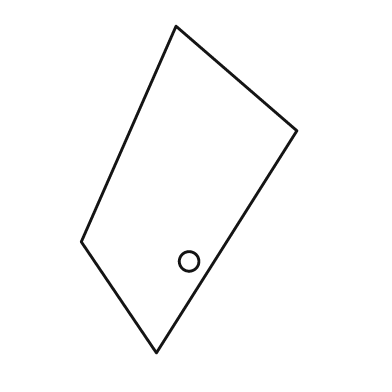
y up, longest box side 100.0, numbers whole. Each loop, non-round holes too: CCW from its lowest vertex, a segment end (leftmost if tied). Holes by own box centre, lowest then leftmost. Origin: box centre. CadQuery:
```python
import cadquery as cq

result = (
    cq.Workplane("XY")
    .moveTo(-10.0, -50.0)
    .lineTo(33.0, 18.0)
    .lineTo(-4.0, 50.0)
    .lineTo(-33.0, -16.0)
    .close()
    .moveTo(0.0, -22.0)
    .circle(3.0)
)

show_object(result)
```